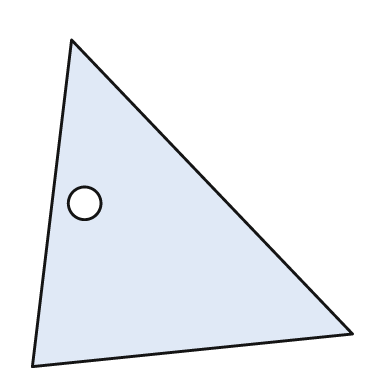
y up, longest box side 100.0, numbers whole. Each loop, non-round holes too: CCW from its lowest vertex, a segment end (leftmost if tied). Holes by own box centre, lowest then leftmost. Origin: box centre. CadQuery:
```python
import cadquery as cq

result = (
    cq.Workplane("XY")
    .moveTo(-49.0, -50.0)
    .lineTo(49.0, -40.0)
    .lineTo(-37.0, 50.0)
    .close()
    .moveTo(-33.0, 0.0)
    .circle(5.0)
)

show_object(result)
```